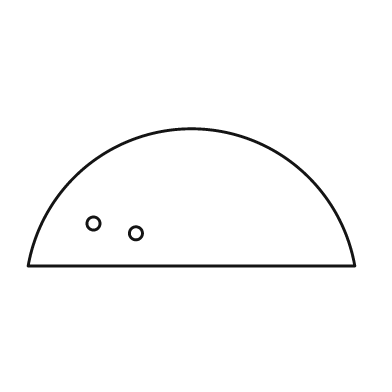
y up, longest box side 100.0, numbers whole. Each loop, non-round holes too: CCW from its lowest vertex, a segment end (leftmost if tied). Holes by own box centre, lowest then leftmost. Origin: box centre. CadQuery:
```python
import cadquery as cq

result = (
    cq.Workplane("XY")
    .moveTo(-50.0, -21.0)
    .lineTo(50.0, -21.0)
    .threePointArc((0.0, 21.0), (-50.0, -21.0))
    .close()
    .moveTo(-17.0, -11.0)
    .circle(2.0)
    .moveTo(-30.0, -8.0)
    .circle(2.0)
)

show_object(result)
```